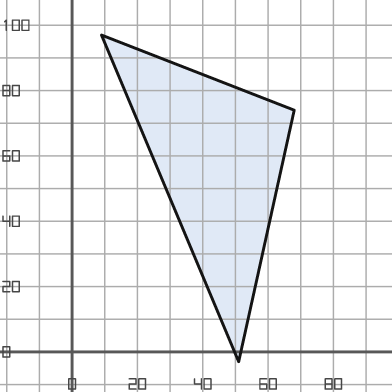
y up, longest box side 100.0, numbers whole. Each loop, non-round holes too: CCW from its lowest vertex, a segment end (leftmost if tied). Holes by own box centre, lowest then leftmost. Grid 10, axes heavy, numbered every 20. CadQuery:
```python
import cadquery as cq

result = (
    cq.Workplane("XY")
    .moveTo(51.0, -3.0)
    .lineTo(68.0, 74.0)
    .lineTo(9.0, 97.0)
    .close()
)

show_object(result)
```